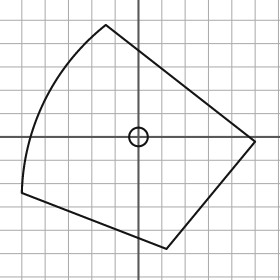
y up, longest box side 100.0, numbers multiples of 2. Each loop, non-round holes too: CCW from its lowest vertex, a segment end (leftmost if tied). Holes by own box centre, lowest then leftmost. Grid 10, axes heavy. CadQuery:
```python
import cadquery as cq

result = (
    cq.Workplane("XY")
    .moveTo(12.0, -48.0)
    .lineTo(50.0, -2.0)
    .lineTo(-14.0, 48.0)
    .threePointArc((-40.0, 16.0), (-50.0, -24.0))
    .close()
    .moveTo(0.0, 0.0)
    .circle(4.0)
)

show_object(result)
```